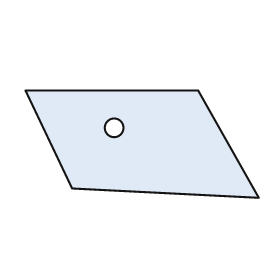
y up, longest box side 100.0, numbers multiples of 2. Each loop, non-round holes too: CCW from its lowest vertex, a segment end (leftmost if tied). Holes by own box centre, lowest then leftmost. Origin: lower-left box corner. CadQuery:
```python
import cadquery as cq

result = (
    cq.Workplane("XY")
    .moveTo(100.0, 0.0)
    .lineTo(74.0, 46.0)
    .lineTo(0.0, 46.0)
    .lineTo(20.0, 4.0)
    .close()
    .moveTo(38.0, 30.0)
    .circle(4.0)
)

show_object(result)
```